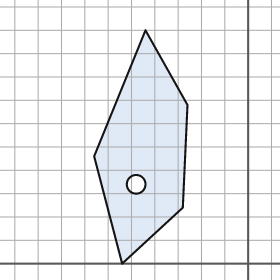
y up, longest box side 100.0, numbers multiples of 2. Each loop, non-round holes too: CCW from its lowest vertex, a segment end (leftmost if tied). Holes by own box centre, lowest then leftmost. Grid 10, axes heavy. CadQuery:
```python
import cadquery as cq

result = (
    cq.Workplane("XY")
    .moveTo(-54.0, 0.0)
    .lineTo(-28.0, 24.0)
    .lineTo(-26.0, 68.0)
    .lineTo(-44.0, 100.0)
    .lineTo(-66.0, 46.0)
    .close()
    .moveTo(-48.0, 34.0)
    .circle(4.0)
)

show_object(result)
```